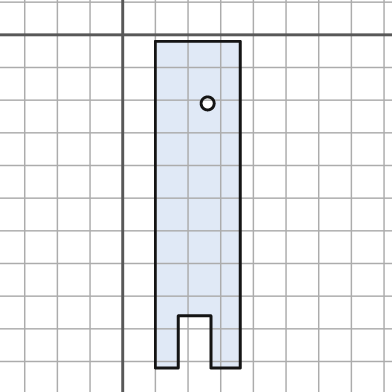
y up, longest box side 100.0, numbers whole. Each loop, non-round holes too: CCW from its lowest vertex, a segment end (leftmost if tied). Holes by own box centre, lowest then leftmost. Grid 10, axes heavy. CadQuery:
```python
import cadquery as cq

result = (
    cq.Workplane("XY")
    .moveTo(10.0, -102.0)
    .lineTo(17.0, -102.0)
    .lineTo(17.0, -86.0)
    .lineTo(27.0, -86.0)
    .lineTo(27.0, -102.0)
    .lineTo(36.0, -102.0)
    .lineTo(36.0, -2.0)
    .lineTo(10.0, -2.0)
    .close()
    .moveTo(26.0, -21.0)
    .circle(2.0)
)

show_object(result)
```